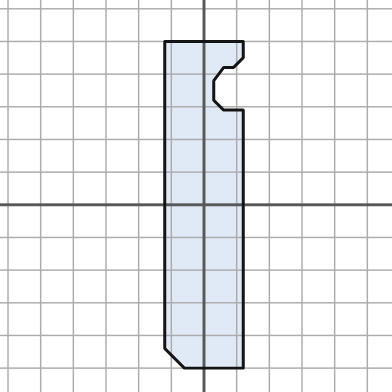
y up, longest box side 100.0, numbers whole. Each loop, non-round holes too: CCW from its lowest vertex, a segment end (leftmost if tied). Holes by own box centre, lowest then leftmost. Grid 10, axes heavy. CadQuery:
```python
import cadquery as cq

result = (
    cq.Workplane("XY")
    .moveTo(-6.0, -50.0)
    .lineTo(12.0, -50.0)
    .lineTo(12.0, 29.0)
    .lineTo(6.0, 29.0)
    .lineTo(3.0, 32.0)
    .lineTo(3.0, 38.0)
    .lineTo(6.0, 42.0)
    .lineTo(9.0, 42.0)
    .lineTo(12.0, 45.0)
    .lineTo(12.0, 50.0)
    .lineTo(-12.0, 50.0)
    .lineTo(-12.0, -44.0)
    .close()
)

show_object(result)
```